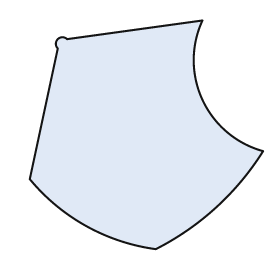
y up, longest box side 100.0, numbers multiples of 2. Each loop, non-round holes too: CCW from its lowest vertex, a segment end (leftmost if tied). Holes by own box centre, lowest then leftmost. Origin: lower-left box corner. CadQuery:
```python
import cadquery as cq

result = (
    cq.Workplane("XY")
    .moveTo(54.0, 0.0)
    .threePointArc((80.0, 18.0), (100.0, 42.0))
    .threePointArc((74.0, 64.0), (74.0, 98.0))
    .lineTo(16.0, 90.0)
    .threePointArc((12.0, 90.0), (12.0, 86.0))
    .lineTo(0.0, 30.0)
    .threePointArc((24.0, 10.0), (54.0, 0.0))
    .close()
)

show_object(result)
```